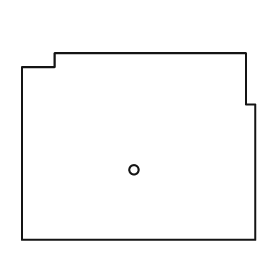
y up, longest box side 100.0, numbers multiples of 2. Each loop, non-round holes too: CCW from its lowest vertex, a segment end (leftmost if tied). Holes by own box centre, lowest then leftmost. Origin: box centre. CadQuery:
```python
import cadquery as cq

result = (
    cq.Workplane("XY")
    .moveTo(-50.0, -40.0)
    .lineTo(50.0, -40.0)
    .lineTo(50.0, 18.0)
    .lineTo(46.0, 18.0)
    .lineTo(46.0, 40.0)
    .lineTo(-36.0, 40.0)
    .lineTo(-36.0, 34.0)
    .lineTo(-50.0, 34.0)
    .close()
    .moveTo(-2.0, -10.0)
    .circle(2.0)
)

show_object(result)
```